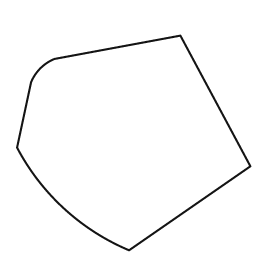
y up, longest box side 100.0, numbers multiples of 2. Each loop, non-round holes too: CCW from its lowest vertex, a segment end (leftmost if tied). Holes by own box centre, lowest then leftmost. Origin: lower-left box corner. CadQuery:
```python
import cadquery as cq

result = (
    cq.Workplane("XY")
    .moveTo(48.0, 0.0)
    .lineTo(100.0, 36.0)
    .lineTo(70.0, 92.0)
    .lineTo(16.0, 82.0)
    .threePointArc((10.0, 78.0), (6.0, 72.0))
    .lineTo(0.0, 44.0)
    .threePointArc((20.0, 18.0), (48.0, 0.0))
    .close()
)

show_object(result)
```